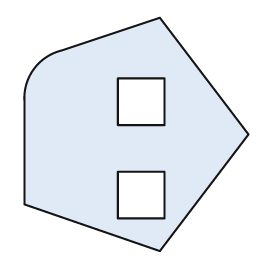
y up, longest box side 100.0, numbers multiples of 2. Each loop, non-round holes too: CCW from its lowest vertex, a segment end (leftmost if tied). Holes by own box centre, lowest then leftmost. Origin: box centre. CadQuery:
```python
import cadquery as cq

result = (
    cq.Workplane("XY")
    .moveTo(10.0, -50.0)
    .lineTo(48.0, 0.0)
    .lineTo(10.0, 50.0)
    .lineTo(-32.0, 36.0)
    .threePointArc((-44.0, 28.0), (-48.0, 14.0))
    .lineTo(-48.0, -30.0)
    .close()
    .moveTo(-8.0, -36.0)
    .lineTo(12.0, -36.0)
    .lineTo(12.0, -16.0)
    .lineTo(-8.0, -16.0)
    .close()
    .moveTo(-8.0, 4.0)
    .lineTo(12.0, 4.0)
    .lineTo(12.0, 24.0)
    .lineTo(-8.0, 24.0)
    .close()
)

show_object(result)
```